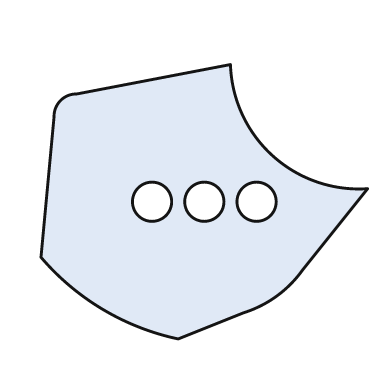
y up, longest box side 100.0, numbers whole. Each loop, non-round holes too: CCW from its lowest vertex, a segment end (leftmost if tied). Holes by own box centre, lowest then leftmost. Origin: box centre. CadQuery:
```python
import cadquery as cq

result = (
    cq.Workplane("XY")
    .moveTo(-8.0, -42.0)
    .lineTo(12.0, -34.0)
    .threePointArc((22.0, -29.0), (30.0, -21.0))
    .lineTo(50.0, 4.0)
    .threePointArc((21.0, 14.0), (8.0, 42.0))
    .lineTo(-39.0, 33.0)
    .threePointArc((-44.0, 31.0), (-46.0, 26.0))
    .lineTo(-50.0, -17.0)
    .threePointArc((-31.0, -33.0), (-8.0, -42.0))
    .close()
    .moveTo(-16.0, 0.0)
    .circle(6.0)
    .moveTo(0.0, 0.0)
    .circle(6.0)
    .moveTo(16.0, 0.0)
    .circle(6.0)
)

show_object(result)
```